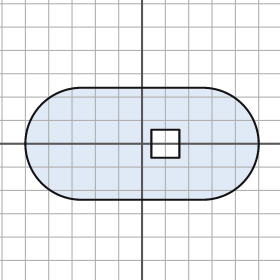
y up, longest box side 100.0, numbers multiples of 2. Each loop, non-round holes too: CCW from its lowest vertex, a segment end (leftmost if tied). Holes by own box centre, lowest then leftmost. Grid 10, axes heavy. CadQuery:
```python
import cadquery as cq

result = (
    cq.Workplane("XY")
    .moveTo(-26.0, -24.0)
    .lineTo(26.0, -24.0)
    .threePointArc((50.0, 0.0), (26.0, 24.0))
    .lineTo(-26.0, 24.0)
    .threePointArc((-50.0, 0.0), (-26.0, -24.0))
    .close()
    .moveTo(4.0, -6.0)
    .lineTo(16.0, -6.0)
    .lineTo(16.0, 6.0)
    .lineTo(4.0, 6.0)
    .close()
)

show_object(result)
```